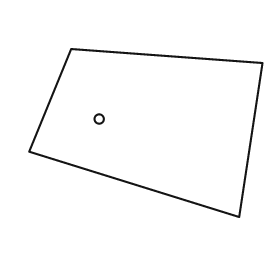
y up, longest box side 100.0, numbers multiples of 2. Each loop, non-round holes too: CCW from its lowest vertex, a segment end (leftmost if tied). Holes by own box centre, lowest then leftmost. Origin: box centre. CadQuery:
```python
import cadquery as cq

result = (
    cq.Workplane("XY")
    .moveTo(40.0, -36.0)
    .lineTo(50.0, 30.0)
    .lineTo(-32.0, 36.0)
    .lineTo(-50.0, -8.0)
    .close()
    .moveTo(-20.0, 6.0)
    .circle(2.0)
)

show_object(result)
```